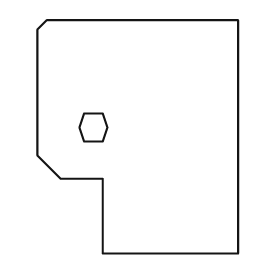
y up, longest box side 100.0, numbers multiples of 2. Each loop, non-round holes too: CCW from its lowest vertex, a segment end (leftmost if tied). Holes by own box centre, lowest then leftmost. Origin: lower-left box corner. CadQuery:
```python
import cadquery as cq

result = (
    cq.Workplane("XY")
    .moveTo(28.0, 0.0)
    .lineTo(86.0, 0.0)
    .lineTo(86.0, 100.0)
    .lineTo(4.0, 100.0)
    .lineTo(0.0, 96.0)
    .lineTo(0.0, 42.0)
    .lineTo(10.0, 32.0)
    .lineTo(28.0, 32.0)
    .close()
    .moveTo(20.0, 48.0)
    .lineTo(28.0, 48.0)
    .lineTo(30.0, 54.0)
    .lineTo(28.0, 60.0)
    .lineTo(20.0, 60.0)
    .lineTo(18.0, 54.0)
    .close()
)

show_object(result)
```